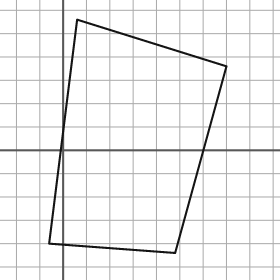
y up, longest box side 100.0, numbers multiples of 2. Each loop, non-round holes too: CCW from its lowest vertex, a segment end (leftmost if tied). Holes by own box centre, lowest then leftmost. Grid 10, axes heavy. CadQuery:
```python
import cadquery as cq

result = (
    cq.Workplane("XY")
    .moveTo(48.0, -44.0)
    .lineTo(70.0, 36.0)
    .lineTo(6.0, 56.0)
    .lineTo(-6.0, -40.0)
    .close()
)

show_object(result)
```